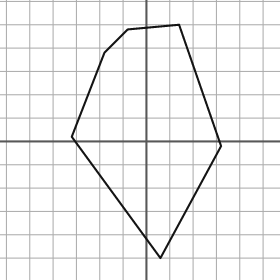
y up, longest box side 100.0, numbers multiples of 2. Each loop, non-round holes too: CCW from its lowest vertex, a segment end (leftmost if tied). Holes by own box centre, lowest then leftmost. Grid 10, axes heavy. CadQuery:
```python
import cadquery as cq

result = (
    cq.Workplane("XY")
    .moveTo(6.0, -50.0)
    .lineTo(32.0, -2.0)
    .lineTo(14.0, 50.0)
    .lineTo(-8.0, 48.0)
    .lineTo(-18.0, 38.0)
    .lineTo(-32.0, 2.0)
    .close()
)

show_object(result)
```